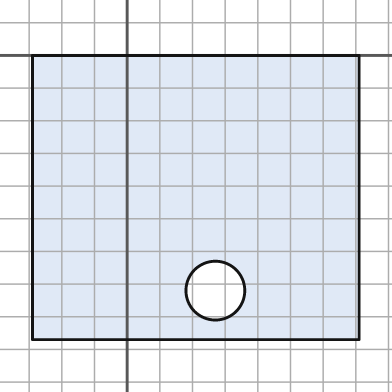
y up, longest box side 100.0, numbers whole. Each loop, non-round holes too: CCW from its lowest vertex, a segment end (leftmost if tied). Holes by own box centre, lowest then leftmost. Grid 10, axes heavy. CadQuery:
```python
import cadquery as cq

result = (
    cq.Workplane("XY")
    .moveTo(-29.0, -87.0)
    .lineTo(71.0, -87.0)
    .lineTo(71.0, 0.0)
    .lineTo(-29.0, 0.0)
    .close()
    .moveTo(27.0, -72.0)
    .circle(9.0)
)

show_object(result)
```